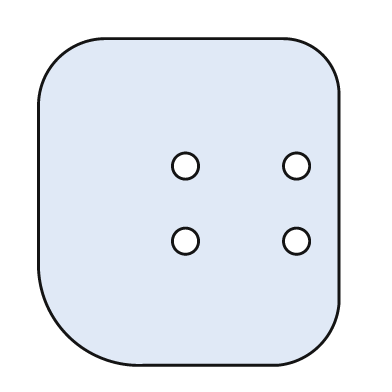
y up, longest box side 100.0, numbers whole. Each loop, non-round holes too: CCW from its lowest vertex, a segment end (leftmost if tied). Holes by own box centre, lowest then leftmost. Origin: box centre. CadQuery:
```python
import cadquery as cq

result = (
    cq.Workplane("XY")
    .moveTo(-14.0, -50.0)
    .lineTo(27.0, -50.0)
    .threePointArc((40.0, -44.0), (46.0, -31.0))
    .lineTo(46.0, 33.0)
    .threePointArc((41.0, 45.0), (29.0, 50.0))
    .lineTo(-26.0, 50.0)
    .threePointArc((-40.0, 44.0), (-46.0, 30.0))
    .lineTo(-46.0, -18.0)
    .threePointArc((-37.0, -41.0), (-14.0, -50.0))
    .close()
    .moveTo(-1.0, -12.0)
    .circle(4.0)
    .moveTo(33.0, -12.0)
    .circle(4.0)
    .moveTo(-1.0, 11.0)
    .circle(4.0)
    .moveTo(33.0, 11.0)
    .circle(4.0)
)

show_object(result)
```